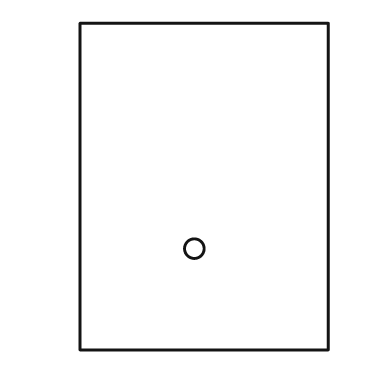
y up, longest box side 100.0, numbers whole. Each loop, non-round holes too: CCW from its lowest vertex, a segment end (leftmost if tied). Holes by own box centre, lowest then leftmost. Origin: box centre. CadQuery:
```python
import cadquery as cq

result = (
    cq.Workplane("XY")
    .moveTo(-38.0, -50.0)
    .lineTo(38.0, -50.0)
    .lineTo(38.0, 50.0)
    .lineTo(-38.0, 50.0)
    .close()
    .moveTo(-3.0, -19.0)
    .circle(3.0)
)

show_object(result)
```